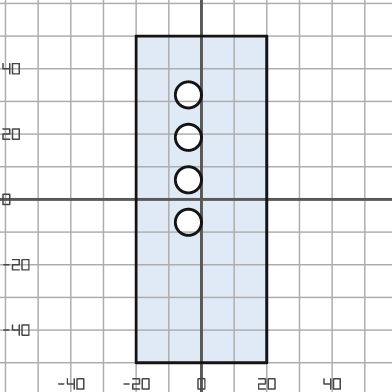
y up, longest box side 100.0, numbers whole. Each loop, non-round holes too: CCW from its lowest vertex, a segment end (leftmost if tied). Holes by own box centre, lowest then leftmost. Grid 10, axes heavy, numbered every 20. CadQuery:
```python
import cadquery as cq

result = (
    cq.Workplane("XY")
    .moveTo(-20.0, -50.0)
    .lineTo(20.0, -50.0)
    .lineTo(20.0, 50.0)
    .lineTo(-20.0, 50.0)
    .close()
    .moveTo(-4.0, -7.0)
    .circle(4.0)
    .moveTo(-4.0, 6.0)
    .circle(4.0)
    .moveTo(-4.0, 19.0)
    .circle(4.0)
    .moveTo(-4.0, 32.0)
    .circle(4.0)
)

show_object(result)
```